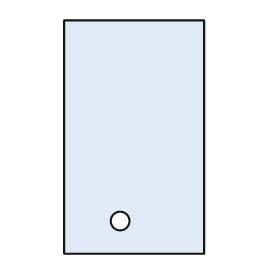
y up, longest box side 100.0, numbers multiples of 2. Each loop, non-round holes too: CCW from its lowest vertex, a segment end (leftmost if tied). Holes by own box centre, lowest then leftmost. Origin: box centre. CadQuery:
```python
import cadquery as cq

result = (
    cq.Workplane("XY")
    .moveTo(-30.0, -50.0)
    .lineTo(30.0, -50.0)
    .lineTo(30.0, 50.0)
    .lineTo(-30.0, 50.0)
    .close()
    .moveTo(-6.0, -36.0)
    .circle(4.0)
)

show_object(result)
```